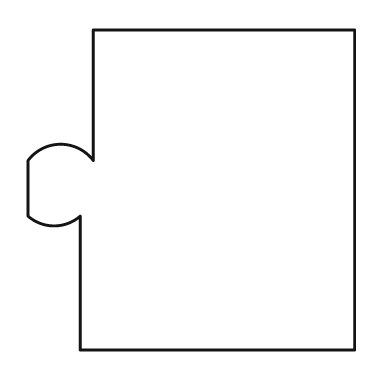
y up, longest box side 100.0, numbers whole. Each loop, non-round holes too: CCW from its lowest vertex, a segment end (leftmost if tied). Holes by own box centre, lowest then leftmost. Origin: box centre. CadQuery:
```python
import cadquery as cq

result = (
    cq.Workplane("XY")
    .moveTo(-34.0, -49.0)
    .lineTo(50.0, -49.0)
    .lineTo(50.0, 49.0)
    .lineTo(-30.0, 49.0)
    .lineTo(-30.0, 9.0)
    .threePointArc((-40.0, 14.0), (-50.0, 9.0))
    .lineTo(-50.0, -8.0)
    .threePointArc((-42.0, -11.0), (-34.0, -8.0))
    .close()
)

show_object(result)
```